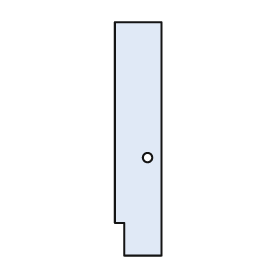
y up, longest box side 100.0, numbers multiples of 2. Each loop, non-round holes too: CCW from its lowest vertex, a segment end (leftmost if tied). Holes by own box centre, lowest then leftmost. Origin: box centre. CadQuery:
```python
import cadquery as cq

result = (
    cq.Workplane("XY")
    .moveTo(-6.0, -50.0)
    .lineTo(10.0, -50.0)
    .lineTo(10.0, 50.0)
    .lineTo(-10.0, 50.0)
    .lineTo(-10.0, -36.0)
    .lineTo(-6.0, -36.0)
    .close()
    .moveTo(4.0, -8.0)
    .circle(2.0)
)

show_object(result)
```